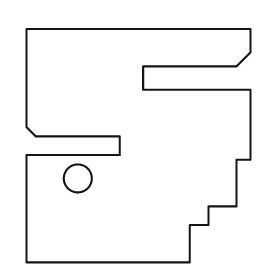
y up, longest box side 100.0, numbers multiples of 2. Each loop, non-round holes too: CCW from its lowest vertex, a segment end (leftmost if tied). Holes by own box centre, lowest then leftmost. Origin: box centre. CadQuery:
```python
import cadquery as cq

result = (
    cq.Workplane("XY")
    .moveTo(-48.0, -50.0)
    .lineTo(22.0, -50.0)
    .lineTo(22.0, -34.0)
    .lineTo(30.0, -34.0)
    .lineTo(30.0, -26.0)
    .lineTo(42.0, -26.0)
    .lineTo(42.0, -6.0)
    .lineTo(48.0, -6.0)
    .lineTo(48.0, 24.0)
    .lineTo(2.0, 24.0)
    .lineTo(2.0, 34.0)
    .lineTo(42.0, 34.0)
    .lineTo(48.0, 40.0)
    .lineTo(48.0, 50.0)
    .lineTo(-48.0, 50.0)
    .lineTo(-48.0, 8.0)
    .lineTo(-44.0, 4.0)
    .lineTo(-8.0, 4.0)
    .lineTo(-8.0, -4.0)
    .lineTo(-48.0, -4.0)
    .close()
    .moveTo(-26.0, -14.0)
    .circle(6.0)
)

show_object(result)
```